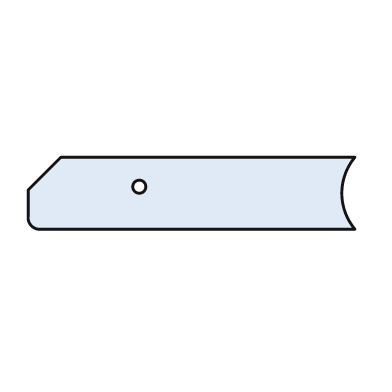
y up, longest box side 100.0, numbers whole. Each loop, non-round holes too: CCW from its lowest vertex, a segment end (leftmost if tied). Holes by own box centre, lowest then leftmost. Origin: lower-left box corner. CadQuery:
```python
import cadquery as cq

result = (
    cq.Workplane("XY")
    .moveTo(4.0, 0.0)
    .lineTo(100.0, 0.0)
    .threePointArc((96.0, 11.0), (100.0, 22.0))
    .lineTo(10.0, 22.0)
    .lineTo(0.0, 12.0)
    .lineTo(0.0, 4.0)
    .threePointArc((1.0, 1.0), (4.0, 0.0))
    .close()
    .moveTo(34.0, 13.0)
    .circle(2.0)
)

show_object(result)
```